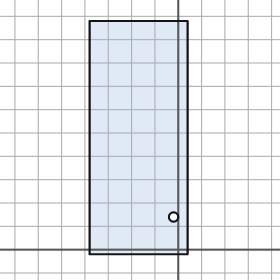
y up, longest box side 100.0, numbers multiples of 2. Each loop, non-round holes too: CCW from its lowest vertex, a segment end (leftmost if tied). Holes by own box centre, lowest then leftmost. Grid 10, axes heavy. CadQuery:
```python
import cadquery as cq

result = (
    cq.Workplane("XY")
    .moveTo(-38.0, -2.0)
    .lineTo(4.0, -2.0)
    .lineTo(4.0, 98.0)
    .lineTo(-38.0, 98.0)
    .close()
    .moveTo(-2.0, 14.0)
    .circle(2.0)
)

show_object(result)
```